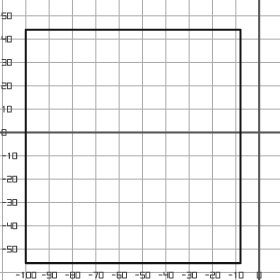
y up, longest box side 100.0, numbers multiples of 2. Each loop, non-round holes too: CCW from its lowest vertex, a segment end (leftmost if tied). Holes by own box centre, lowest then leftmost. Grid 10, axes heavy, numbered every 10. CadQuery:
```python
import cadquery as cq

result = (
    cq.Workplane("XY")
    .moveTo(-100.0, -56.0)
    .lineTo(-8.0, -56.0)
    .lineTo(-8.0, 44.0)
    .lineTo(-100.0, 44.0)
    .close()
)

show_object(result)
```